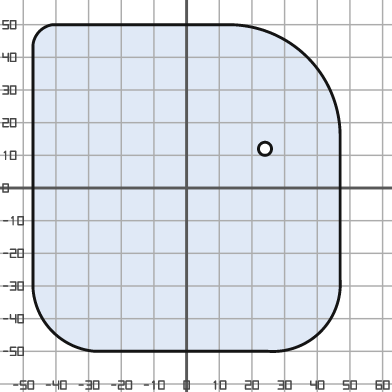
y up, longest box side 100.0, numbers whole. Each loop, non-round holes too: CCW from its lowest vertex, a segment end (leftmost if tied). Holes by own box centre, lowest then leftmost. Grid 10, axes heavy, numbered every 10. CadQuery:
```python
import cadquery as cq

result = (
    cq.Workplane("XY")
    .moveTo(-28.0, -50.0)
    .lineTo(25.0, -50.0)
    .threePointArc((41.0, -44.0), (47.0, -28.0))
    .lineTo(47.0, 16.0)
    .threePointArc((37.0, 40.0), (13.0, 50.0))
    .lineTo(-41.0, 50.0)
    .threePointArc((-45.0, 48.0), (-47.0, 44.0))
    .lineTo(-47.0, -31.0)
    .threePointArc((-41.0, -44.0), (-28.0, -50.0))
    .close()
    .moveTo(24.0, 12.0)
    .circle(2.0)
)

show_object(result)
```